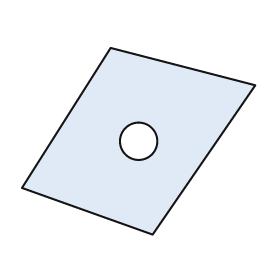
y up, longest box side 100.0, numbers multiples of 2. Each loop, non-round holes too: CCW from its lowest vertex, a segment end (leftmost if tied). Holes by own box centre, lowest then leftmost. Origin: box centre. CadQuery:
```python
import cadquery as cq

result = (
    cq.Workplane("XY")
    .moveTo(6.0, -40.0)
    .lineTo(50.0, 24.0)
    .lineTo(-12.0, 40.0)
    .lineTo(-50.0, -20.0)
    .close()
    .moveTo(0.0, 0.0)
    .circle(8.0)
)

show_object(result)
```